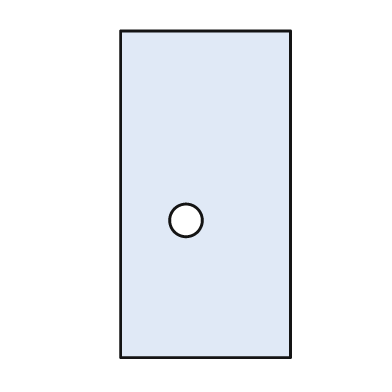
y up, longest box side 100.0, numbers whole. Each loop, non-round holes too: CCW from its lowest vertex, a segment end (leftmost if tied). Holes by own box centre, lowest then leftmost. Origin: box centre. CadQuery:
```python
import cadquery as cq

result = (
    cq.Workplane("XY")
    .moveTo(-26.0, -50.0)
    .lineTo(26.0, -50.0)
    .lineTo(26.0, 50.0)
    .lineTo(-26.0, 50.0)
    .close()
    .moveTo(-6.0, -8.0)
    .circle(5.0)
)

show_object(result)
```